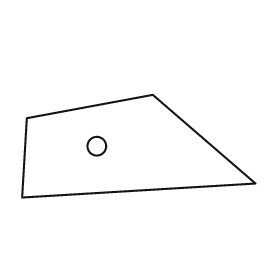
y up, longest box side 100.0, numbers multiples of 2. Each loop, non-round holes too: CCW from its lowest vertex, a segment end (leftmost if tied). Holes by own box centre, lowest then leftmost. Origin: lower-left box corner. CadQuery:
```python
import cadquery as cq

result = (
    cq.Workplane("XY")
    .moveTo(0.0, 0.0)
    .lineTo(100.0, 6.0)
    .lineTo(56.0, 44.0)
    .lineTo(2.0, 34.0)
    .close()
    .moveTo(32.0, 22.0)
    .circle(4.0)
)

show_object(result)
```